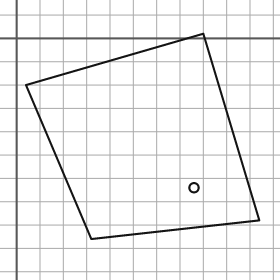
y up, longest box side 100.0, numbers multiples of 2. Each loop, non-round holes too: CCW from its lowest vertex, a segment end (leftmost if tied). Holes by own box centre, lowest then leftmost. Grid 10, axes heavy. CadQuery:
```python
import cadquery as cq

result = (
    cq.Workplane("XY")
    .moveTo(32.0, -86.0)
    .lineTo(104.0, -78.0)
    .lineTo(80.0, 2.0)
    .lineTo(4.0, -20.0)
    .close()
    .moveTo(76.0, -64.0)
    .circle(2.0)
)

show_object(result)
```